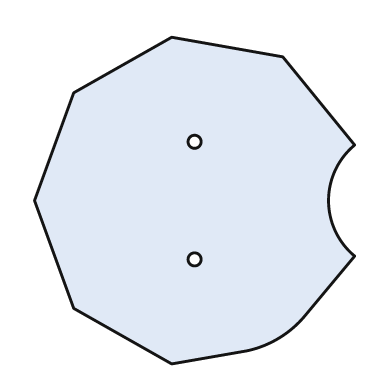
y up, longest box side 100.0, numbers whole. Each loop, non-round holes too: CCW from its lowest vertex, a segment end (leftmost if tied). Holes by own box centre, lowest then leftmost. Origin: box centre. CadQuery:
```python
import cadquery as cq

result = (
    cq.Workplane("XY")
    .moveTo(-7.0, -50.0)
    .lineTo(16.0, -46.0)
    .threePointArc((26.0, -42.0), (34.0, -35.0))
    .lineTo(49.0, -17.0)
    .threePointArc((41.0, 0.0), (49.0, 17.0))
    .lineTo(27.0, 44.0)
    .lineTo(-7.0, 50.0)
    .lineTo(-37.0, 33.0)
    .lineTo(-49.0, 0.0)
    .lineTo(-37.0, -33.0)
    .close()
    .moveTo(0.0, -18.0)
    .circle(2.0)
    .moveTo(0.0, 18.0)
    .circle(2.0)
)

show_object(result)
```